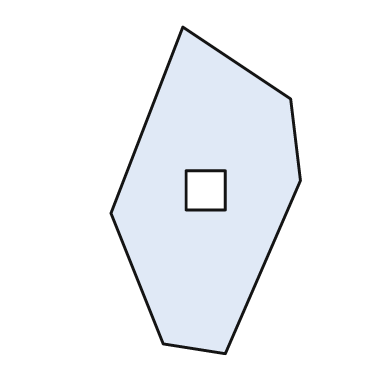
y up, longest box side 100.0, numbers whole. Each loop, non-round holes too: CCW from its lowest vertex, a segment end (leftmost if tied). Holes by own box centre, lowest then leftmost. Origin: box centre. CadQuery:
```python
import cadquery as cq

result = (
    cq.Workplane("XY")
    .moveTo(6.0, -50.0)
    .lineTo(29.0, 3.0)
    .lineTo(26.0, 28.0)
    .lineTo(-7.0, 50.0)
    .lineTo(-29.0, -7.0)
    .lineTo(-13.0, -47.0)
    .close()
    .moveTo(-6.0, -6.0)
    .lineTo(6.0, -6.0)
    .lineTo(6.0, 6.0)
    .lineTo(-6.0, 6.0)
    .close()
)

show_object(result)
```